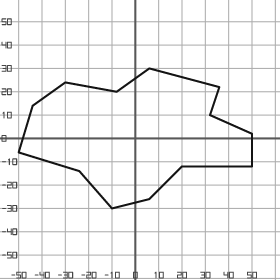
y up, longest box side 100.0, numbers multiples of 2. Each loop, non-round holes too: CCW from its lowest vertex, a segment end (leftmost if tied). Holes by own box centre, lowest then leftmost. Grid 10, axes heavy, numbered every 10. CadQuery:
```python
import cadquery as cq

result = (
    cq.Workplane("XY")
    .moveTo(-10.0, -30.0)
    .lineTo(6.0, -26.0)
    .lineTo(20.0, -12.0)
    .lineTo(50.0, -12.0)
    .lineTo(50.0, 2.0)
    .lineTo(32.0, 10.0)
    .lineTo(36.0, 22.0)
    .lineTo(6.0, 30.0)
    .lineTo(-8.0, 20.0)
    .lineTo(-30.0, 24.0)
    .lineTo(-44.0, 14.0)
    .lineTo(-50.0, -6.0)
    .lineTo(-24.0, -14.0)
    .close()
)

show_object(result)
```